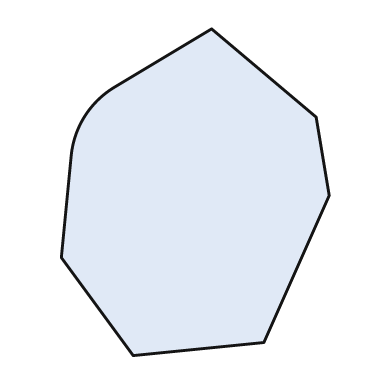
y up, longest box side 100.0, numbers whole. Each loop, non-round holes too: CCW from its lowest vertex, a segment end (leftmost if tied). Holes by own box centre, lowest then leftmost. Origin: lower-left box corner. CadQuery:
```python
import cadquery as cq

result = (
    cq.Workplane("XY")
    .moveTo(22.0, 0.0)
    .lineTo(62.0, 4.0)
    .lineTo(82.0, 49.0)
    .lineTo(78.0, 73.0)
    .lineTo(46.0, 100.0)
    .lineTo(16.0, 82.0)
    .threePointArc((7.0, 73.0), (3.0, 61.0))
    .lineTo(0.0, 30.0)
    .close()
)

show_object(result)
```